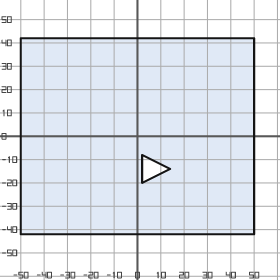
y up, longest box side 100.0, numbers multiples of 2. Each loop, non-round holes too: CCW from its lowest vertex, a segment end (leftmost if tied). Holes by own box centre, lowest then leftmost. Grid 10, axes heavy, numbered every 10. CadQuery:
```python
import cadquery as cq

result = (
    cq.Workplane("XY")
    .moveTo(-50.0, -42.0)
    .lineTo(50.0, -42.0)
    .lineTo(50.0, 42.0)
    .lineTo(-50.0, 42.0)
    .close()
    .moveTo(2.0, -20.0)
    .lineTo(14.0, -14.0)
    .lineTo(2.0, -8.0)
    .close()
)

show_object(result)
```